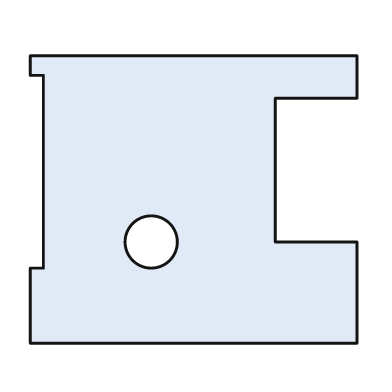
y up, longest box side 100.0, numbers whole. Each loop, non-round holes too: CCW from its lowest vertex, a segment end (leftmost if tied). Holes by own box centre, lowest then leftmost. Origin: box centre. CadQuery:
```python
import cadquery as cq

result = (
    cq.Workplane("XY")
    .moveTo(-50.0, -44.0)
    .lineTo(50.0, -44.0)
    .lineTo(50.0, -13.0)
    .lineTo(25.0, -13.0)
    .lineTo(25.0, 31.0)
    .lineTo(50.0, 31.0)
    .lineTo(50.0, 44.0)
    .lineTo(-50.0, 44.0)
    .lineTo(-50.0, 38.0)
    .lineTo(-46.0, 38.0)
    .lineTo(-46.0, -21.0)
    .lineTo(-50.0, -21.0)
    .close()
    .moveTo(-13.0, -13.0)
    .circle(8.0)
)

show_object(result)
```